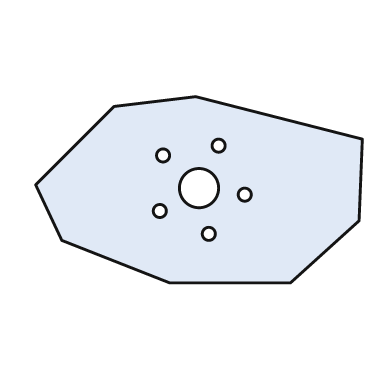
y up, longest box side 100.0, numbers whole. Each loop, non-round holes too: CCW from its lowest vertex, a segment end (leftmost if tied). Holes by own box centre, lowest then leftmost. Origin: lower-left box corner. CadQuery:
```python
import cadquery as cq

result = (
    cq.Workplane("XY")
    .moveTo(41.0, 0.0)
    .lineTo(78.0, 0.0)
    .lineTo(99.0, 19.0)
    .lineTo(100.0, 44.0)
    .lineTo(49.0, 57.0)
    .lineTo(24.0, 54.0)
    .lineTo(0.0, 30.0)
    .lineTo(8.0, 13.0)
    .close()
    .moveTo(53.0, 15.0)
    .circle(2.0)
    .moveTo(38.0, 22.0)
    .circle(2.0)
    .moveTo(64.0, 27.0)
    .circle(2.0)
    .moveTo(50.0, 29.0)
    .circle(6.0)
    .moveTo(39.0, 39.0)
    .circle(2.0)
    .moveTo(56.0, 42.0)
    .circle(2.0)
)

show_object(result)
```